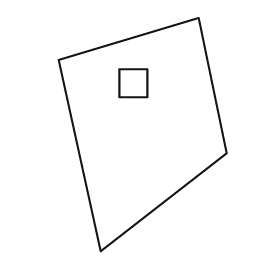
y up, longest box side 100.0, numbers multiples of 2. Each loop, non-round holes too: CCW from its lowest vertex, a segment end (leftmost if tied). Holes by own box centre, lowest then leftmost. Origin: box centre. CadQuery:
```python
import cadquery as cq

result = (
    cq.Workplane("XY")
    .moveTo(-18.0, -50.0)
    .lineTo(36.0, -8.0)
    .lineTo(24.0, 50.0)
    .lineTo(-36.0, 32.0)
    .close()
    .moveTo(-10.0, 16.0)
    .lineTo(2.0, 16.0)
    .lineTo(2.0, 28.0)
    .lineTo(-10.0, 28.0)
    .close()
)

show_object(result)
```